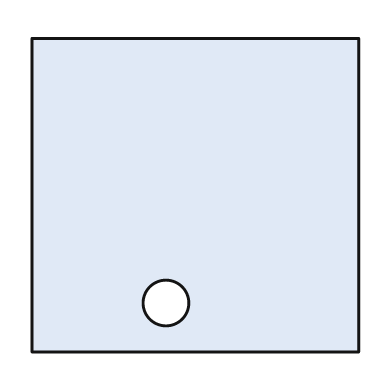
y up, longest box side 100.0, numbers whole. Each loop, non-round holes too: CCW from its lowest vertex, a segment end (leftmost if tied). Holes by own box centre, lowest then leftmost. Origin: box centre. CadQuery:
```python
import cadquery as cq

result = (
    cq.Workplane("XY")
    .moveTo(-50.0, -48.0)
    .lineTo(50.0, -48.0)
    .lineTo(50.0, 48.0)
    .lineTo(-50.0, 48.0)
    .close()
    .moveTo(-9.0, -33.0)
    .circle(7.0)
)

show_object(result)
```